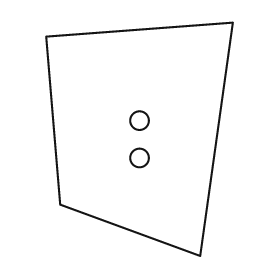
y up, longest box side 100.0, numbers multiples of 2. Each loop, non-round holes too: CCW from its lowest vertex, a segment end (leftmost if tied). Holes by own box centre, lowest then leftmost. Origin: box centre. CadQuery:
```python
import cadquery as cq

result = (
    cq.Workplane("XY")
    .moveTo(26.0, -50.0)
    .lineTo(40.0, 50.0)
    .lineTo(-40.0, 44.0)
    .lineTo(-34.0, -28.0)
    .close()
    .moveTo(0.0, -8.0)
    .circle(4.0)
    .moveTo(0.0, 8.0)
    .circle(4.0)
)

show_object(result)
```